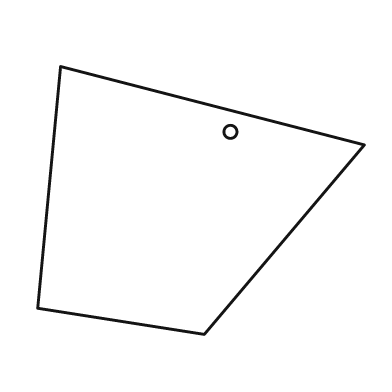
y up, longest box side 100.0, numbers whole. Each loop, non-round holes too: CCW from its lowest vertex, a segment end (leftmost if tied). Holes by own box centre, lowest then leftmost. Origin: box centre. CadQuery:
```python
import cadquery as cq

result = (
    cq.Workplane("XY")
    .moveTo(1.0, -41.0)
    .lineTo(50.0, 17.0)
    .lineTo(-43.0, 41.0)
    .lineTo(-50.0, -33.0)
    .close()
    .moveTo(9.0, 21.0)
    .circle(2.0)
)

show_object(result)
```